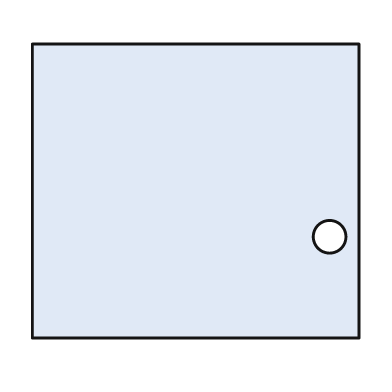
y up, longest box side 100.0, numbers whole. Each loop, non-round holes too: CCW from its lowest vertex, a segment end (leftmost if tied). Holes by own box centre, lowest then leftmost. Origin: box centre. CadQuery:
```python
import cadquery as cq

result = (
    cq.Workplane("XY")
    .moveTo(-50.0, -45.0)
    .lineTo(50.0, -45.0)
    .lineTo(50.0, 45.0)
    .lineTo(-50.0, 45.0)
    .close()
    .moveTo(41.0, -14.0)
    .circle(5.0)
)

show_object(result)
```